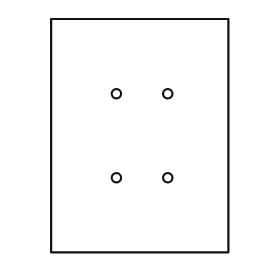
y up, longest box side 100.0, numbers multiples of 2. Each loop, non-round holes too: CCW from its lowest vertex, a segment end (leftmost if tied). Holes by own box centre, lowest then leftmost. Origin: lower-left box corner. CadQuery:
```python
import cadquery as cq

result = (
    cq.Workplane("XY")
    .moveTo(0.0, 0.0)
    .lineTo(76.0, 0.0)
    .lineTo(76.0, 100.0)
    .lineTo(0.0, 100.0)
    .close()
    .moveTo(28.0, 32.0)
    .circle(2.0)
    .moveTo(50.0, 32.0)
    .circle(2.0)
    .moveTo(28.0, 68.0)
    .circle(2.0)
    .moveTo(50.0, 68.0)
    .circle(2.0)
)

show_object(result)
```